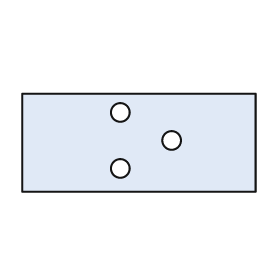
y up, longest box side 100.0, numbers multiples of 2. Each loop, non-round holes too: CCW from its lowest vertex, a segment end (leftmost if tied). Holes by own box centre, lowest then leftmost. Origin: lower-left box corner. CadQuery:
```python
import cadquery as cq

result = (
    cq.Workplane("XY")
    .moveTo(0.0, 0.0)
    .lineTo(100.0, 0.0)
    .lineTo(100.0, 42.0)
    .lineTo(0.0, 42.0)
    .close()
    .moveTo(42.0, 10.0)
    .circle(4.0)
    .moveTo(64.0, 22.0)
    .circle(4.0)
    .moveTo(42.0, 34.0)
    .circle(4.0)
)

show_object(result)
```